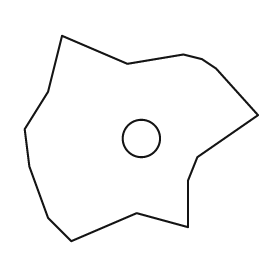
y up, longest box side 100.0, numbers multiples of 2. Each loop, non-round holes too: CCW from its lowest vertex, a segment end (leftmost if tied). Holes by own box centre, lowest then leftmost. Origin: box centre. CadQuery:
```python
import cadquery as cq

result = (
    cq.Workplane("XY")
    .moveTo(-30.0, -44.0)
    .lineTo(-2.0, -32.0)
    .lineTo(20.0, -38.0)
    .lineTo(20.0, -18.0)
    .lineTo(24.0, -8.0)
    .lineTo(50.0, 10.0)
    .lineTo(32.0, 30.0)
    .lineTo(26.0, 34.0)
    .lineTo(18.0, 36.0)
    .lineTo(-6.0, 32.0)
    .lineTo(-34.0, 44.0)
    .lineTo(-40.0, 20.0)
    .lineTo(-50.0, 4.0)
    .lineTo(-48.0, -12.0)
    .lineTo(-40.0, -34.0)
    .close()
    .moveTo(0.0, 0.0)
    .circle(8.0)
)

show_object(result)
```